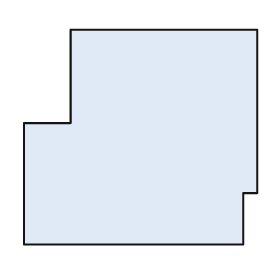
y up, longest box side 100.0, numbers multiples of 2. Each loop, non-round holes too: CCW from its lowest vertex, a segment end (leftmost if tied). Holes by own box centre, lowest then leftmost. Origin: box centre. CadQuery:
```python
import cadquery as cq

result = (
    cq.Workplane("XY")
    .moveTo(-50.0, -46.0)
    .lineTo(44.0, -46.0)
    .lineTo(44.0, -24.0)
    .lineTo(50.0, -24.0)
    .lineTo(50.0, 46.0)
    .lineTo(-30.0, 46.0)
    .lineTo(-30.0, 6.0)
    .lineTo(-50.0, 6.0)
    .close()
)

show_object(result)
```